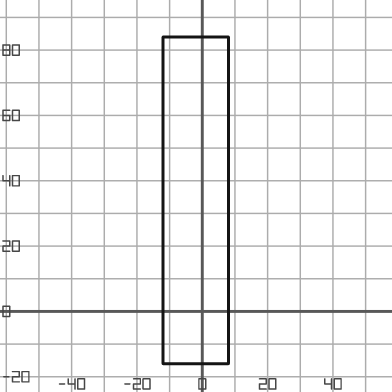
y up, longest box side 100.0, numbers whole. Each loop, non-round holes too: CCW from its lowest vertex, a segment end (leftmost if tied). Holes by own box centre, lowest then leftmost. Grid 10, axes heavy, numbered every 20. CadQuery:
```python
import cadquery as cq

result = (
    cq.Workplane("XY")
    .moveTo(-12.0, -16.0)
    .lineTo(8.0, -16.0)
    .lineTo(8.0, 84.0)
    .lineTo(-12.0, 84.0)
    .close()
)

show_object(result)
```